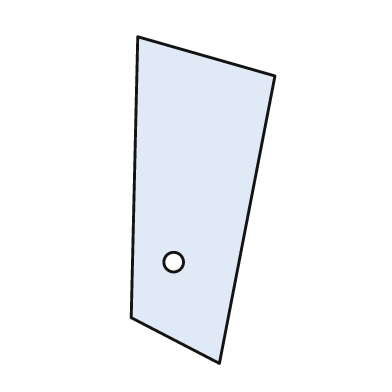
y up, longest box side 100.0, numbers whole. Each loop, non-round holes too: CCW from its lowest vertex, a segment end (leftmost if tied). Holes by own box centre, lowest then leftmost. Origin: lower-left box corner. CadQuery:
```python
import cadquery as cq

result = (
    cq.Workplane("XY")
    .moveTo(27.0, 0.0)
    .lineTo(44.0, 88.0)
    .lineTo(2.0, 100.0)
    .lineTo(0.0, 14.0)
    .close()
    .moveTo(13.0, 31.0)
    .circle(3.0)
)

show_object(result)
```